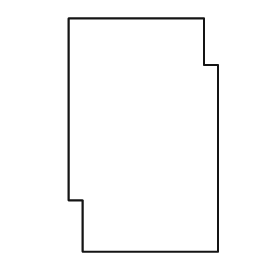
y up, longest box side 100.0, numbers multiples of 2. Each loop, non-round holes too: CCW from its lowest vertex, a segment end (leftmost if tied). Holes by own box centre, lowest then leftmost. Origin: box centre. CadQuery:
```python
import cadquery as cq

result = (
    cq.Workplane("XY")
    .moveTo(-26.0, -50.0)
    .lineTo(32.0, -50.0)
    .lineTo(32.0, 30.0)
    .lineTo(26.0, 30.0)
    .lineTo(26.0, 50.0)
    .lineTo(-32.0, 50.0)
    .lineTo(-32.0, -28.0)
    .lineTo(-26.0, -28.0)
    .close()
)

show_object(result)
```